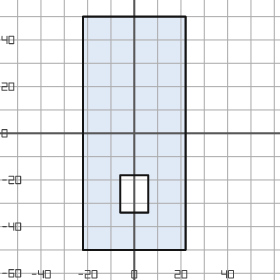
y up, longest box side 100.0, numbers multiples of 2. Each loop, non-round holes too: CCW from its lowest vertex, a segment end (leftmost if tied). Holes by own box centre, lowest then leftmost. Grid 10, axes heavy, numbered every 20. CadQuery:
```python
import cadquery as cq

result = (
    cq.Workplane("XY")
    .moveTo(-22.0, -50.0)
    .lineTo(22.0, -50.0)
    .lineTo(22.0, 50.0)
    .lineTo(-22.0, 50.0)
    .close()
    .moveTo(-6.0, -34.0)
    .lineTo(6.0, -34.0)
    .lineTo(6.0, -18.0)
    .lineTo(-6.0, -18.0)
    .close()
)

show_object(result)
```